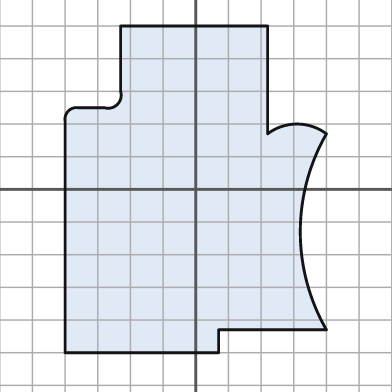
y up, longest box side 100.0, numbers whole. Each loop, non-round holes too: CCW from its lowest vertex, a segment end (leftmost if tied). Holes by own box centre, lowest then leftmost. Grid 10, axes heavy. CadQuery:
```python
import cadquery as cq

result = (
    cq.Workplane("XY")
    .moveTo(-40.0, -50.0)
    .lineTo(7.0, -50.0)
    .lineTo(7.0, -43.0)
    .lineTo(40.0, -43.0)
    .threePointArc((32.0, -13.0), (40.0, 17.0))
    .threePointArc((31.0, 20.0), (22.0, 17.0))
    .lineTo(22.0, 50.0)
    .lineTo(-23.0, 50.0)
    .lineTo(-23.0, 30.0)
    .threePointArc((-24.0, 26.0), (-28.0, 25.0))
    .lineTo(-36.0, 25.0)
    .threePointArc((-39.0, 24.0), (-40.0, 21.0))
    .close()
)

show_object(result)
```